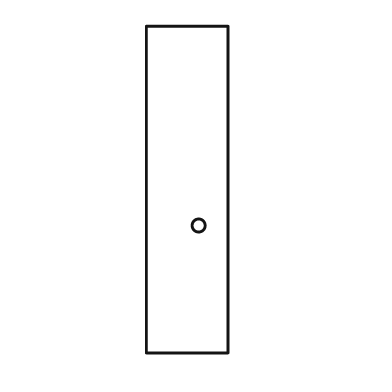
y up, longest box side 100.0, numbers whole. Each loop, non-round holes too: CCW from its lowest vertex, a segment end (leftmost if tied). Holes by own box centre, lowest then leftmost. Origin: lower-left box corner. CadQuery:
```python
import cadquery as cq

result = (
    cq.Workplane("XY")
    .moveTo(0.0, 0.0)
    .lineTo(25.0, 0.0)
    .lineTo(25.0, 100.0)
    .lineTo(0.0, 100.0)
    .close()
    .moveTo(16.0, 39.0)
    .circle(2.0)
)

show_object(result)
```